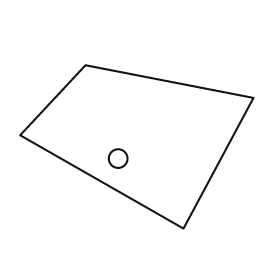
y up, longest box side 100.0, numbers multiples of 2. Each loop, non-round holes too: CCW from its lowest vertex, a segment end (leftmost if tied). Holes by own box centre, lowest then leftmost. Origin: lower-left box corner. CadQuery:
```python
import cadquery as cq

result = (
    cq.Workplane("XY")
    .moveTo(70.0, 0.0)
    .lineTo(100.0, 56.0)
    .lineTo(28.0, 70.0)
    .lineTo(0.0, 40.0)
    .close()
    .moveTo(42.0, 30.0)
    .circle(4.0)
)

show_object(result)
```